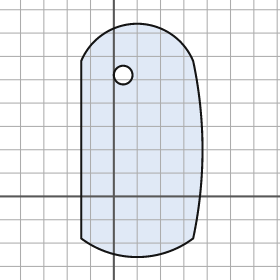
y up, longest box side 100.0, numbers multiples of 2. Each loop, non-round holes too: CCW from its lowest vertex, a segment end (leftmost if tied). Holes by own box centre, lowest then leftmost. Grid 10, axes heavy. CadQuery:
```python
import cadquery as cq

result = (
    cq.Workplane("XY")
    .moveTo(-14.0, -18.0)
    .threePointArc((10.0, -26.0), (34.0, -18.0))
    .threePointArc((38.0, 20.0), (34.0, 58.0))
    .threePointArc((10.0, 74.0), (-14.0, 58.0))
    .close()
    .moveTo(4.0, 52.0)
    .circle(4.0)
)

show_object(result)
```